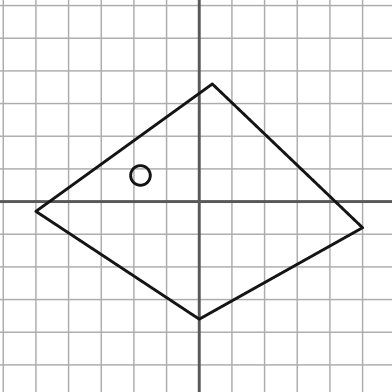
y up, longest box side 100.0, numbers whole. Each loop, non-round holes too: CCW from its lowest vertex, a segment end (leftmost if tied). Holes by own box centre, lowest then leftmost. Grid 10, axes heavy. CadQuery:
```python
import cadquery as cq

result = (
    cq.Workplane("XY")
    .moveTo(0.0, -36.0)
    .lineTo(50.0, -8.0)
    .lineTo(4.0, 36.0)
    .lineTo(-50.0, -3.0)
    .close()
    .moveTo(-18.0, 8.0)
    .circle(3.0)
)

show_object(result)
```